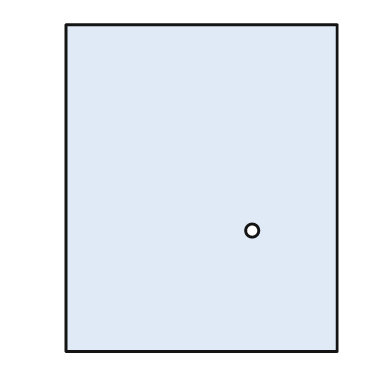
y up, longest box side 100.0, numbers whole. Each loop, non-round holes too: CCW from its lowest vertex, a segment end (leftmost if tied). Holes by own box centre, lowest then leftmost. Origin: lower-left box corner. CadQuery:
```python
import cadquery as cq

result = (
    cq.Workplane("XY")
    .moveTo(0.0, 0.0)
    .lineTo(83.0, 0.0)
    .lineTo(83.0, 100.0)
    .lineTo(0.0, 100.0)
    .close()
    .moveTo(57.0, 37.0)
    .circle(2.0)
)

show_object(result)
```